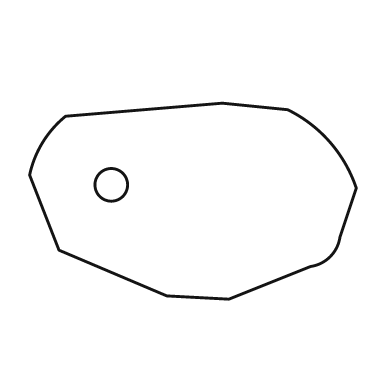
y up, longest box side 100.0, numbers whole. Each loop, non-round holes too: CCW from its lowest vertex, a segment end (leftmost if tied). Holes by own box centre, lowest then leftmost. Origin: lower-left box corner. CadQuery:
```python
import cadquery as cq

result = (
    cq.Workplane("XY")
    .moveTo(61.0, 0.0)
    .lineTo(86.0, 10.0)
    .threePointArc((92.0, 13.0), (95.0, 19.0))
    .lineTo(100.0, 34.0)
    .threePointArc((92.0, 48.0), (79.0, 58.0))
    .lineTo(59.0, 60.0)
    .lineTo(11.0, 56.0)
    .threePointArc((4.0, 48.0), (0.0, 38.0))
    .lineTo(9.0, 15.0)
    .lineTo(42.0, 1.0)
    .close()
    .moveTo(25.0, 35.0)
    .circle(5.0)
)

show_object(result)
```